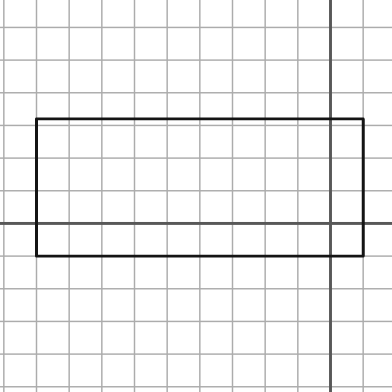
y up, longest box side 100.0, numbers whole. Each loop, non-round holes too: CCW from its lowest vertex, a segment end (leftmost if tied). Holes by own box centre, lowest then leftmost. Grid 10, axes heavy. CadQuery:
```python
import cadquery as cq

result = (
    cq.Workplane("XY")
    .moveTo(-90.0, -10.0)
    .lineTo(10.0, -10.0)
    .lineTo(10.0, 32.0)
    .lineTo(-90.0, 32.0)
    .close()
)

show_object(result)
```